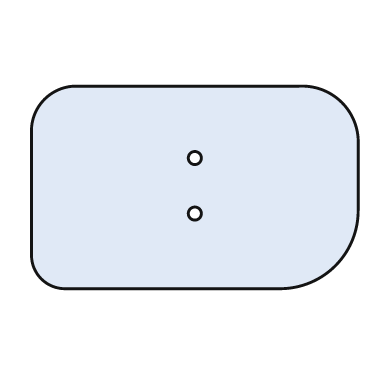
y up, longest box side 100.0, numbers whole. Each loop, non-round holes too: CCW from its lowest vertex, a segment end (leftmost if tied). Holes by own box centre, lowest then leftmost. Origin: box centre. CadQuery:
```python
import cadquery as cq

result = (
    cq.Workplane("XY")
    .moveTo(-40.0, -31.0)
    .lineTo(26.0, -31.0)
    .threePointArc((43.0, -24.0), (50.0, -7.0))
    .lineTo(50.0, 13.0)
    .threePointArc((45.0, 26.0), (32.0, 31.0))
    .lineTo(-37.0, 31.0)
    .threePointArc((-46.0, 27.0), (-50.0, 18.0))
    .lineTo(-50.0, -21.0)
    .threePointArc((-47.0, -28.0), (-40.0, -31.0))
    .close()
    .moveTo(0.0, -8.0)
    .circle(2.0)
    .moveTo(0.0, 9.0)
    .circle(2.0)
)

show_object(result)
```